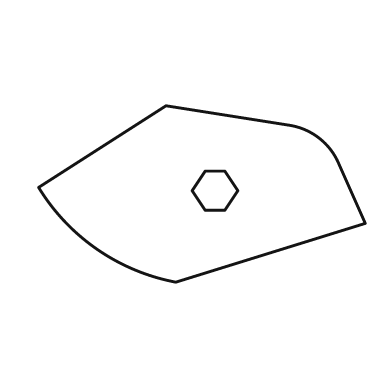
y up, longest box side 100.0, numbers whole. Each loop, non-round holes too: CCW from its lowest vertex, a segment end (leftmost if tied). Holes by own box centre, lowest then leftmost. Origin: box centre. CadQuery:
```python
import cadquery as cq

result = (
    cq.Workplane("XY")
    .moveTo(-8.0, -27.0)
    .lineTo(50.0, -9.0)
    .lineTo(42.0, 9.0)
    .threePointArc((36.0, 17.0), (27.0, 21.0))
    .lineTo(-11.0, 27.0)
    .lineTo(-50.0, 2.0)
    .threePointArc((-32.0, -17.0), (-8.0, -27.0))
    .close()
    .moveTo(1.0, -5.0)
    .lineTo(7.0, -5.0)
    .lineTo(11.0, 1.0)
    .lineTo(7.0, 7.0)
    .lineTo(1.0, 7.0)
    .lineTo(-3.0, 1.0)
    .close()
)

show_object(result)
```